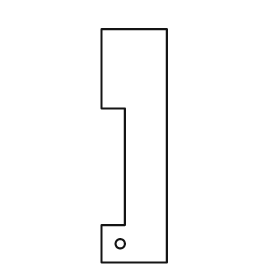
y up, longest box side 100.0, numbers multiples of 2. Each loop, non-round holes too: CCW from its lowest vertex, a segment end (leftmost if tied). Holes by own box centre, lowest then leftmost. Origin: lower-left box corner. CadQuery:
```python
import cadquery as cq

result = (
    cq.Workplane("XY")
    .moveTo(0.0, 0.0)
    .lineTo(28.0, 0.0)
    .lineTo(28.0, 100.0)
    .lineTo(0.0, 100.0)
    .lineTo(0.0, 66.0)
    .lineTo(10.0, 66.0)
    .lineTo(10.0, 16.0)
    .lineTo(0.0, 16.0)
    .close()
    .moveTo(8.0, 8.0)
    .circle(2.0)
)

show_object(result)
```